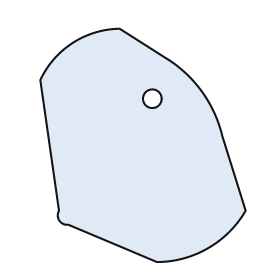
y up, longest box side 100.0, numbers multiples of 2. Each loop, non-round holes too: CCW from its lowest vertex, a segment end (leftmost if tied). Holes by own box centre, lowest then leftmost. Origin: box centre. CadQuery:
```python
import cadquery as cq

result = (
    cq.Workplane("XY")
    .moveTo(6.0, -50.0)
    .threePointArc((28.0, -44.0), (44.0, -28.0))
    .lineTo(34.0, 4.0)
    .threePointArc((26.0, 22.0), (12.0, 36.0))
    .lineTo(-10.0, 50.0)
    .threePointArc((-30.0, 44.0), (-44.0, 28.0))
    .lineTo(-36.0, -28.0)
    .threePointArc((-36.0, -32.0), (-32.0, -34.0))
    .close()
    .moveTo(4.0, 20.0)
    .circle(4.0)
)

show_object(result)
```